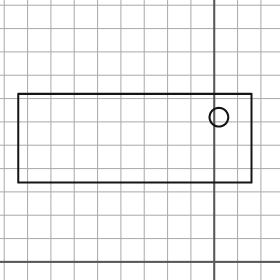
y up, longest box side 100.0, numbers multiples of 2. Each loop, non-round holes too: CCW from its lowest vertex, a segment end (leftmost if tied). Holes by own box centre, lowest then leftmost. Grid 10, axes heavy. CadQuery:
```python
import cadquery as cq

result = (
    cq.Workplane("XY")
    .moveTo(-84.0, 34.0)
    .lineTo(16.0, 34.0)
    .lineTo(16.0, 72.0)
    .lineTo(-84.0, 72.0)
    .close()
    .moveTo(2.0, 62.0)
    .circle(4.0)
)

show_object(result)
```